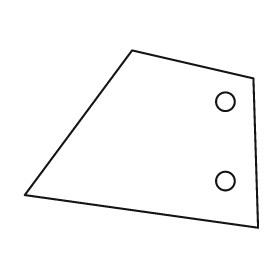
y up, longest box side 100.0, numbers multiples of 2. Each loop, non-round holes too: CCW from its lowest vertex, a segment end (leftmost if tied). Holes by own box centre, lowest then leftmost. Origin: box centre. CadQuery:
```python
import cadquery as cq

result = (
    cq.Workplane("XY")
    .moveTo(50.0, -38.0)
    .lineTo(48.0, 26.0)
    .lineTo(-4.0, 38.0)
    .lineTo(-50.0, -24.0)
    .close()
    .moveTo(36.0, -18.0)
    .circle(4.0)
    .moveTo(36.0, 16.0)
    .circle(4.0)
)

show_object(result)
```